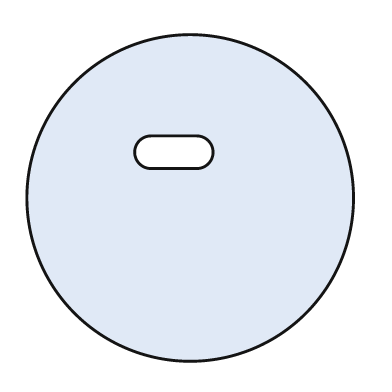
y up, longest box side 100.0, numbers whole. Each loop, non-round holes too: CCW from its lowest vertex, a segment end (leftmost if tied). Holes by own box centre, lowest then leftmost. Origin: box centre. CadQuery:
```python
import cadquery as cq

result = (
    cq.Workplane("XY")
    .moveTo(0.0, 0.0)
    .circle(50.0)
    .moveTo(-12.0, 9.0)
    .lineTo(2.0, 9.0)
    .threePointArc((7.0, 14.0), (2.0, 19.0))
    .lineTo(-12.0, 19.0)
    .threePointArc((-17.0, 14.0), (-12.0, 9.0))
    .close()
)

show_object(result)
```